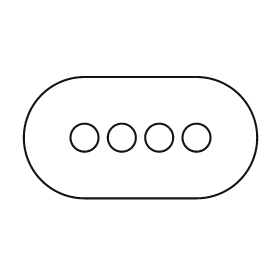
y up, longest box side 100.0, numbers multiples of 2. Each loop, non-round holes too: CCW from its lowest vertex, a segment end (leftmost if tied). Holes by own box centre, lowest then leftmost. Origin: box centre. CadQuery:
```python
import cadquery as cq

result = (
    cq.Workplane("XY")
    .moveTo(-24.0, -26.0)
    .lineTo(24.0, -26.0)
    .threePointArc((50.0, 0.0), (24.0, 26.0))
    .lineTo(-24.0, 26.0)
    .threePointArc((-50.0, 0.0), (-24.0, -26.0))
    .close()
    .moveTo(-24.0, 0.0)
    .circle(6.0)
    .moveTo(-8.0, 0.0)
    .circle(6.0)
    .moveTo(8.0, 0.0)
    .circle(6.0)
    .moveTo(24.0, 0.0)
    .circle(6.0)
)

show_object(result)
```